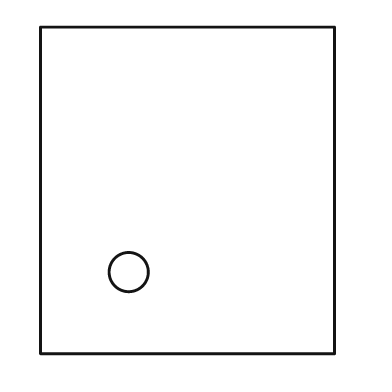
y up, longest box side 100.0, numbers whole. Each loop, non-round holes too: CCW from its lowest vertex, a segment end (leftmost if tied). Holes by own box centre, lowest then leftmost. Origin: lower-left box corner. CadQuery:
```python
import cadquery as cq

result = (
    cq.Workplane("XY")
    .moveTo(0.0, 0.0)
    .lineTo(90.0, 0.0)
    .lineTo(90.0, 100.0)
    .lineTo(0.0, 100.0)
    .close()
    .moveTo(27.0, 25.0)
    .circle(6.0)
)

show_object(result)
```